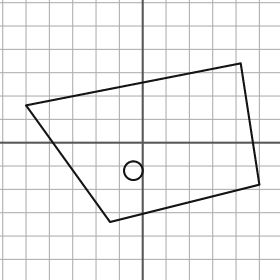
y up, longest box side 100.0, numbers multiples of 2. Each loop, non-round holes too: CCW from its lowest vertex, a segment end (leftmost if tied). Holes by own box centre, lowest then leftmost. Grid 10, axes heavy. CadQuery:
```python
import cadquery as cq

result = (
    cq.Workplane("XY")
    .moveTo(-14.0, -34.0)
    .lineTo(50.0, -18.0)
    .lineTo(42.0, 34.0)
    .lineTo(-50.0, 16.0)
    .close()
    .moveTo(-4.0, -12.0)
    .circle(4.0)
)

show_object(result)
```